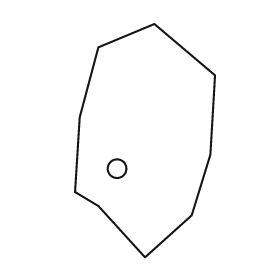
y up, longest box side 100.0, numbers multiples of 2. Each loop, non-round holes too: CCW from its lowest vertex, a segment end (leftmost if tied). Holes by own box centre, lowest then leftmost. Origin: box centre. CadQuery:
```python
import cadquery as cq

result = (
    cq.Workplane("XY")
    .moveTo(0.0, -50.0)
    .lineTo(20.0, -32.0)
    .lineTo(28.0, -6.0)
    .lineTo(30.0, 28.0)
    .lineTo(4.0, 50.0)
    .lineTo(-20.0, 40.0)
    .lineTo(-28.0, 10.0)
    .lineTo(-30.0, -22.0)
    .lineTo(-20.0, -28.0)
    .close()
    .moveTo(-12.0, -12.0)
    .circle(4.0)
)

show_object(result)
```